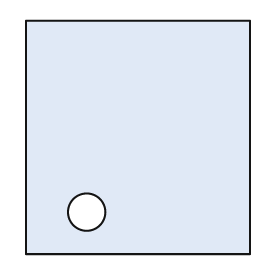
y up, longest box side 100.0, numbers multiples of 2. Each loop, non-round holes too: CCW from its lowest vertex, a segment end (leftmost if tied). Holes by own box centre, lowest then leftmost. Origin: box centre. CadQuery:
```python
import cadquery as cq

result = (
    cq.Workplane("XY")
    .moveTo(-48.0, -50.0)
    .lineTo(48.0, -50.0)
    .lineTo(48.0, 50.0)
    .lineTo(-48.0, 50.0)
    .close()
    .moveTo(-22.0, -32.0)
    .circle(8.0)
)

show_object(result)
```